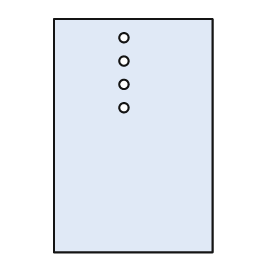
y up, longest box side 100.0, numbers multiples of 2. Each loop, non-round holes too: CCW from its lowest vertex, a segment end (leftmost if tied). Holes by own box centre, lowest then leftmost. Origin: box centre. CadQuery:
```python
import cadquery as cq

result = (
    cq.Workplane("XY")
    .moveTo(-34.0, -50.0)
    .lineTo(34.0, -50.0)
    .lineTo(34.0, 50.0)
    .lineTo(-34.0, 50.0)
    .close()
    .moveTo(-4.0, 12.0)
    .circle(2.0)
    .moveTo(-4.0, 22.0)
    .circle(2.0)
    .moveTo(-4.0, 32.0)
    .circle(2.0)
    .moveTo(-4.0, 42.0)
    .circle(2.0)
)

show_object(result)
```